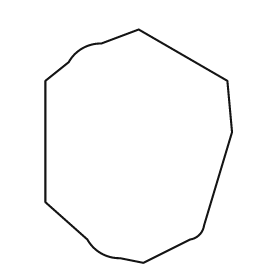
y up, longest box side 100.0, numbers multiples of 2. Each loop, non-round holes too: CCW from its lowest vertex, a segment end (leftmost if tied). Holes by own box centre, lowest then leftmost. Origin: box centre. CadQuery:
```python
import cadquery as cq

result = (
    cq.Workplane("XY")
    .moveTo(2.0, -50.0)
    .lineTo(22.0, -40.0)
    .threePointArc((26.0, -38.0), (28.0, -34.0))
    .lineTo(40.0, 6.0)
    .lineTo(38.0, 28.0)
    .lineTo(0.0, 50.0)
    .lineTo(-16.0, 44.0)
    .threePointArc((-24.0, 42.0), (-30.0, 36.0))
    .lineTo(-40.0, 28.0)
    .lineTo(-40.0, -24.0)
    .lineTo(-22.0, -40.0)
    .threePointArc((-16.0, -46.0), (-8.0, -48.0))
    .close()
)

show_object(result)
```